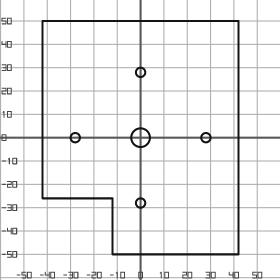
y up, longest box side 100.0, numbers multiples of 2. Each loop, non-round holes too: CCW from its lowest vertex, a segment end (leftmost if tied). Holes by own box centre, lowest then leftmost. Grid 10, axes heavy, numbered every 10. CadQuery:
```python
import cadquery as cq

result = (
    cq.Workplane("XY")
    .moveTo(-12.0, -50.0)
    .lineTo(42.0, -50.0)
    .lineTo(42.0, 50.0)
    .lineTo(-42.0, 50.0)
    .lineTo(-42.0, -26.0)
    .lineTo(-12.0, -26.0)
    .close()
    .moveTo(0.0, -28.0)
    .circle(2.0)
    .moveTo(-28.0, 0.0)
    .circle(2.0)
    .moveTo(0.0, 0.0)
    .circle(4.0)
    .moveTo(28.0, 0.0)
    .circle(2.0)
    .moveTo(0.0, 28.0)
    .circle(2.0)
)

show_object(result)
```